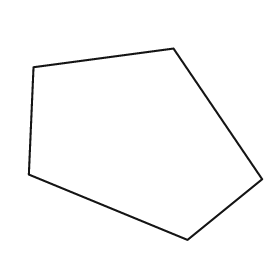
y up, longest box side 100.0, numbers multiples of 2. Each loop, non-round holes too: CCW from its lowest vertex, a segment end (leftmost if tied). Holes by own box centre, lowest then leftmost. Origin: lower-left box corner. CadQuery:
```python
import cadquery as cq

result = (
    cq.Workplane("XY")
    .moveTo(68.0, 0.0)
    .lineTo(100.0, 26.0)
    .lineTo(62.0, 82.0)
    .lineTo(2.0, 74.0)
    .lineTo(0.0, 28.0)
    .close()
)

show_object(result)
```